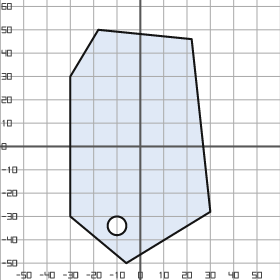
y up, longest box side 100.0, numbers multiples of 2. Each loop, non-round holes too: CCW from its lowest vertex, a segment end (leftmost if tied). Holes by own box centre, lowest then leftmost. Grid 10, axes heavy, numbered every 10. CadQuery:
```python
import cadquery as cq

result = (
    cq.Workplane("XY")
    .moveTo(-6.0, -50.0)
    .lineTo(30.0, -28.0)
    .lineTo(22.0, 46.0)
    .lineTo(-18.0, 50.0)
    .lineTo(-30.0, 30.0)
    .lineTo(-30.0, -30.0)
    .close()
    .moveTo(-10.0, -34.0)
    .circle(4.0)
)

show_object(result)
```